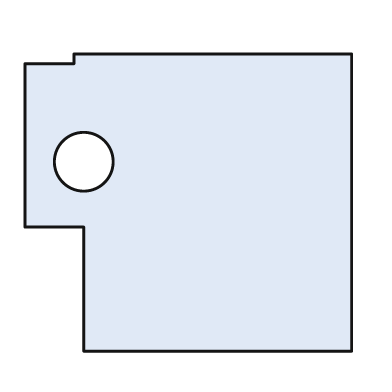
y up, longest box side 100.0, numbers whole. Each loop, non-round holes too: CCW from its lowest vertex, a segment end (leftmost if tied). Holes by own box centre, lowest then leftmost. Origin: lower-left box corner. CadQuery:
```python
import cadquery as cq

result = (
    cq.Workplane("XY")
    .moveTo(18.0, 0.0)
    .lineTo(100.0, 0.0)
    .lineTo(100.0, 91.0)
    .lineTo(15.0, 91.0)
    .lineTo(15.0, 88.0)
    .lineTo(0.0, 88.0)
    .lineTo(0.0, 38.0)
    .lineTo(18.0, 38.0)
    .close()
    .moveTo(18.0, 58.0)
    .circle(9.0)
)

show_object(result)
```